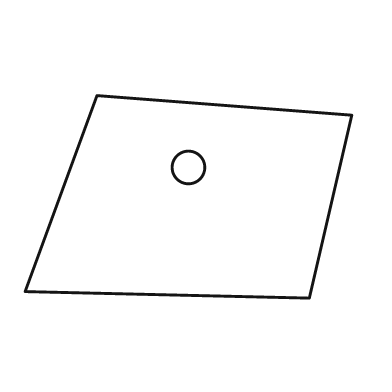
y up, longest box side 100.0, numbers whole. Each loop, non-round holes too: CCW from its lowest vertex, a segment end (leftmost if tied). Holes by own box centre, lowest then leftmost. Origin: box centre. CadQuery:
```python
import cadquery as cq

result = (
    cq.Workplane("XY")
    .moveTo(37.0, -31.0)
    .lineTo(50.0, 25.0)
    .lineTo(-28.0, 31.0)
    .lineTo(-50.0, -29.0)
    .close()
    .moveTo(0.0, 9.0)
    .circle(5.0)
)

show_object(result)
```